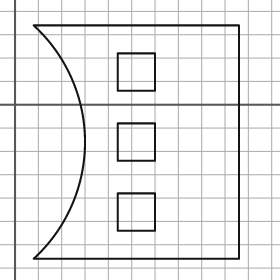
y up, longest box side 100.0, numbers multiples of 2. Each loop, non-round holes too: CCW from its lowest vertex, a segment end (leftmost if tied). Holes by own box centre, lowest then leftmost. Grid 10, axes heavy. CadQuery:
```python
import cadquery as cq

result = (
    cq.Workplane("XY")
    .moveTo(8.0, -66.0)
    .lineTo(96.0, -66.0)
    .lineTo(96.0, 34.0)
    .lineTo(8.0, 34.0)
    .threePointArc((30.0, -16.0), (8.0, -66.0))
    .close()
    .moveTo(44.0, -54.0)
    .lineTo(60.0, -54.0)
    .lineTo(60.0, -38.0)
    .lineTo(44.0, -38.0)
    .close()
    .moveTo(44.0, -24.0)
    .lineTo(60.0, -24.0)
    .lineTo(60.0, -8.0)
    .lineTo(44.0, -8.0)
    .close()
    .moveTo(44.0, 6.0)
    .lineTo(60.0, 6.0)
    .lineTo(60.0, 22.0)
    .lineTo(44.0, 22.0)
    .close()
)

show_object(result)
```